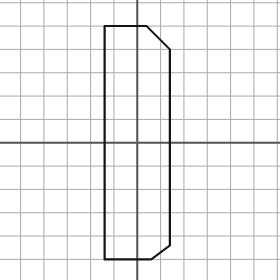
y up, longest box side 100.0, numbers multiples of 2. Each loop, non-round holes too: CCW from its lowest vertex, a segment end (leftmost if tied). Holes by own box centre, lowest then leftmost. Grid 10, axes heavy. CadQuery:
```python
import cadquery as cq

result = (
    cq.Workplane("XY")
    .moveTo(-14.0, -50.0)
    .lineTo(6.0, -50.0)
    .lineTo(14.0, -44.0)
    .lineTo(14.0, 40.0)
    .lineTo(4.0, 50.0)
    .lineTo(-14.0, 50.0)
    .close()
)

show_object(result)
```